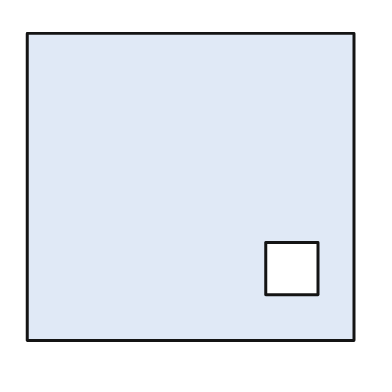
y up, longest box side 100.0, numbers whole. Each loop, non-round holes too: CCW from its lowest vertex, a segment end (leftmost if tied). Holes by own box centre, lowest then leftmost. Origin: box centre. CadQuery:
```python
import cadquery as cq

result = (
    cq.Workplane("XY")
    .moveTo(-50.0, -47.0)
    .lineTo(50.0, -47.0)
    .lineTo(50.0, 47.0)
    .lineTo(-50.0, 47.0)
    .close()
    .moveTo(23.0, -33.0)
    .lineTo(39.0, -33.0)
    .lineTo(39.0, -17.0)
    .lineTo(23.0, -17.0)
    .close()
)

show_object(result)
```